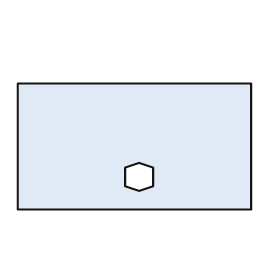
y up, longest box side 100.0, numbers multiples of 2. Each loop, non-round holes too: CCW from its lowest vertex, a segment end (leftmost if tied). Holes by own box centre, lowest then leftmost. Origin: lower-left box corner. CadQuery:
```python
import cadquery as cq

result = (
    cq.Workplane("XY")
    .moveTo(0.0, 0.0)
    .lineTo(100.0, 0.0)
    .lineTo(100.0, 54.0)
    .lineTo(0.0, 54.0)
    .close()
    .moveTo(52.0, 8.0)
    .lineTo(58.0, 10.0)
    .lineTo(58.0, 18.0)
    .lineTo(52.0, 20.0)
    .lineTo(46.0, 18.0)
    .lineTo(46.0, 10.0)
    .close()
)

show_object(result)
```